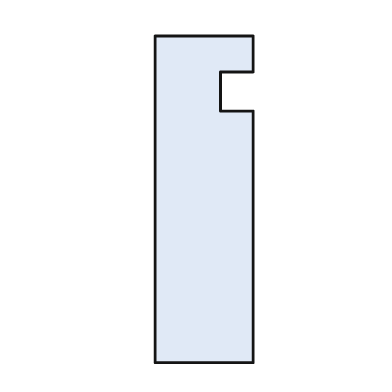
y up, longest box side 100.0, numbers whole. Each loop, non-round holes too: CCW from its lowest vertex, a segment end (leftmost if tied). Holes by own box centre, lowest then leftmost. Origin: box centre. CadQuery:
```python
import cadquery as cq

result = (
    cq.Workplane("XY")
    .moveTo(-15.0, -50.0)
    .lineTo(15.0, -50.0)
    .lineTo(15.0, 27.0)
    .lineTo(5.0, 27.0)
    .lineTo(5.0, 39.0)
    .lineTo(15.0, 39.0)
    .lineTo(15.0, 50.0)
    .lineTo(-15.0, 50.0)
    .close()
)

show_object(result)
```